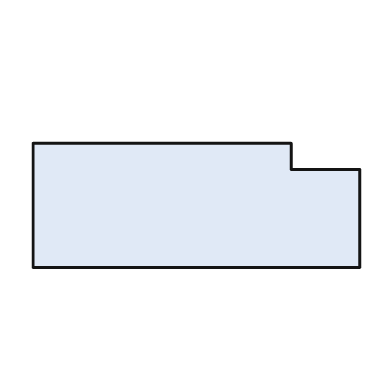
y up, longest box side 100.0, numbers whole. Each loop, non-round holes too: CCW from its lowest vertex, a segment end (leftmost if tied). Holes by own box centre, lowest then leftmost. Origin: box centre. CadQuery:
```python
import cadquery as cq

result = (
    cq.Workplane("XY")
    .moveTo(-50.0, -19.0)
    .lineTo(50.0, -19.0)
    .lineTo(50.0, 11.0)
    .lineTo(29.0, 11.0)
    .lineTo(29.0, 19.0)
    .lineTo(-50.0, 19.0)
    .close()
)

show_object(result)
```